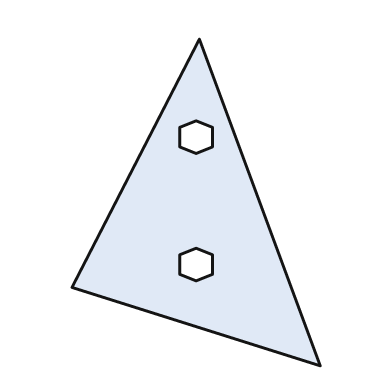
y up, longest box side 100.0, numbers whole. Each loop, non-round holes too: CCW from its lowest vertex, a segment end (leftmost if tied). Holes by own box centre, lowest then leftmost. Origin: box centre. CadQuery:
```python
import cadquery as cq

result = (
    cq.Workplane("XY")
    .moveTo(38.0, -50.0)
    .lineTo(1.0, 50.0)
    .lineTo(-38.0, -26.0)
    .close()
    .moveTo(0.0, -24.0)
    .lineTo(5.0, -22.0)
    .lineTo(5.0, -16.0)
    .lineTo(0.0, -14.0)
    .lineTo(-5.0, -16.0)
    .lineTo(-5.0, -22.0)
    .close()
    .moveTo(0.0, 15.0)
    .lineTo(5.0, 17.0)
    .lineTo(5.0, 23.0)
    .lineTo(0.0, 25.0)
    .lineTo(-5.0, 23.0)
    .lineTo(-5.0, 17.0)
    .close()
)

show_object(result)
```